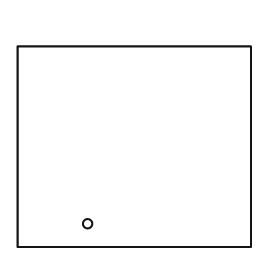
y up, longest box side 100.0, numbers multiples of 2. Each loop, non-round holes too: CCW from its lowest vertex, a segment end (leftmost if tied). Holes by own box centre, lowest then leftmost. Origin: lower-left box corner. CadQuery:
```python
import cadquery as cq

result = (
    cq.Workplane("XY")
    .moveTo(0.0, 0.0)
    .lineTo(100.0, 0.0)
    .lineTo(100.0, 86.0)
    .lineTo(0.0, 86.0)
    .close()
    .moveTo(30.0, 10.0)
    .circle(2.0)
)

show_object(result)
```